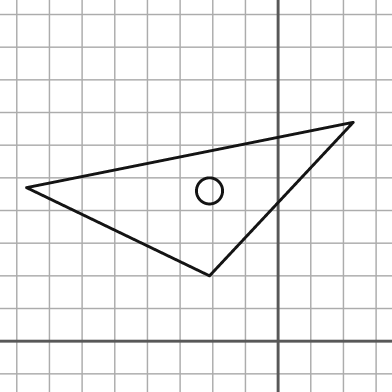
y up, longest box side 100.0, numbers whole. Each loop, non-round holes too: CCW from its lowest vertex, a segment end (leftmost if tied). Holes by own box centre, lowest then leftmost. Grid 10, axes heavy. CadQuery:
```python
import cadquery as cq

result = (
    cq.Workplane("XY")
    .moveTo(-21.0, 20.0)
    .lineTo(23.0, 67.0)
    .lineTo(-77.0, 47.0)
    .close()
    .moveTo(-21.0, 46.0)
    .circle(4.0)
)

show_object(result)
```